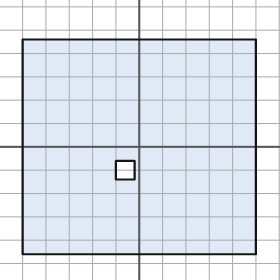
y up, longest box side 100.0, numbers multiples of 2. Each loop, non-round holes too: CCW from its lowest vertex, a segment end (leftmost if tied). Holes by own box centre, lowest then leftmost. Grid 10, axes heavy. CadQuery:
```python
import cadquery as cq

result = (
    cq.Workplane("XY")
    .moveTo(-50.0, -46.0)
    .lineTo(50.0, -46.0)
    .lineTo(50.0, 46.0)
    .lineTo(-50.0, 46.0)
    .close()
    .moveTo(-10.0, -14.0)
    .lineTo(-2.0, -14.0)
    .lineTo(-2.0, -6.0)
    .lineTo(-10.0, -6.0)
    .close()
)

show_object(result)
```